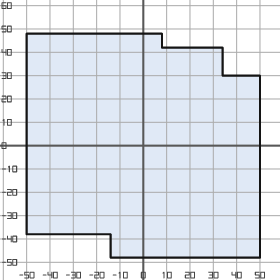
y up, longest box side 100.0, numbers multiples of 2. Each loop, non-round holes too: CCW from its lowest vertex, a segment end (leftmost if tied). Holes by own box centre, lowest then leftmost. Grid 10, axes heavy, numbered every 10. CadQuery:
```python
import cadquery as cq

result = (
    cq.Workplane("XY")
    .moveTo(-14.0, -48.0)
    .lineTo(50.0, -48.0)
    .lineTo(50.0, 30.0)
    .lineTo(34.0, 30.0)
    .lineTo(34.0, 42.0)
    .lineTo(8.0, 42.0)
    .lineTo(8.0, 48.0)
    .lineTo(-50.0, 48.0)
    .lineTo(-50.0, -38.0)
    .lineTo(-14.0, -38.0)
    .close()
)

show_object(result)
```